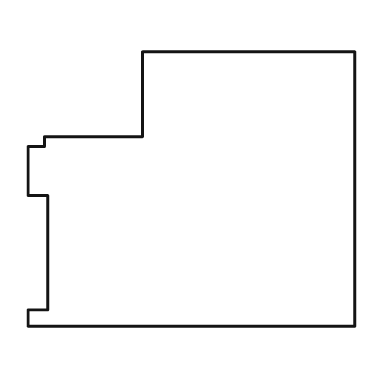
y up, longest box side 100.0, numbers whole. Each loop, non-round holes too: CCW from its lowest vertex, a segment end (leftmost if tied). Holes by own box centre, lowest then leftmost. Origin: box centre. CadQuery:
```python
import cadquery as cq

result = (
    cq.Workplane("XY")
    .moveTo(-50.0, -42.0)
    .lineTo(50.0, -42.0)
    .lineTo(50.0, 42.0)
    .lineTo(-15.0, 42.0)
    .lineTo(-15.0, 16.0)
    .lineTo(-45.0, 16.0)
    .lineTo(-45.0, 13.0)
    .lineTo(-50.0, 13.0)
    .lineTo(-50.0, -2.0)
    .lineTo(-44.0, -2.0)
    .lineTo(-44.0, -37.0)
    .lineTo(-50.0, -37.0)
    .close()
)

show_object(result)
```